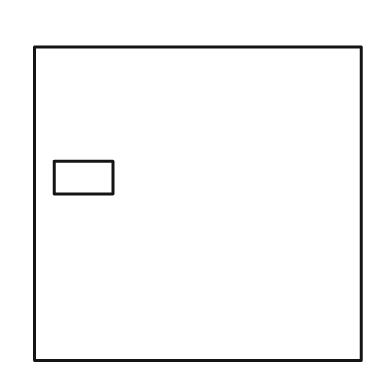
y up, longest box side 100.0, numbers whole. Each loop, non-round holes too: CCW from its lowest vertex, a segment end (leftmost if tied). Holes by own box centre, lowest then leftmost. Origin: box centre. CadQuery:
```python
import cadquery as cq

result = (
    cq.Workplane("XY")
    .moveTo(-50.0, -48.0)
    .lineTo(50.0, -48.0)
    .lineTo(50.0, 48.0)
    .lineTo(-50.0, 48.0)
    .close()
    .moveTo(-44.0, 3.0)
    .lineTo(-26.0, 3.0)
    .lineTo(-26.0, 13.0)
    .lineTo(-44.0, 13.0)
    .close()
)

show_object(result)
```